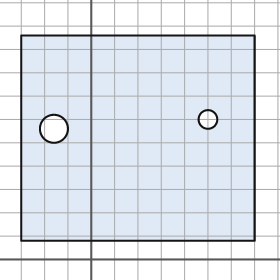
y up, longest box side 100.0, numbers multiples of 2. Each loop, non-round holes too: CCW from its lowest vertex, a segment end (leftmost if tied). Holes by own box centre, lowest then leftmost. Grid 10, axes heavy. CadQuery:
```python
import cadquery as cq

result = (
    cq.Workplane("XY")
    .moveTo(-30.0, 8.0)
    .lineTo(70.0, 8.0)
    .lineTo(70.0, 96.0)
    .lineTo(-30.0, 96.0)
    .close()
    .moveTo(-16.0, 56.0)
    .circle(6.0)
    .moveTo(50.0, 60.0)
    .circle(4.0)
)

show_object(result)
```